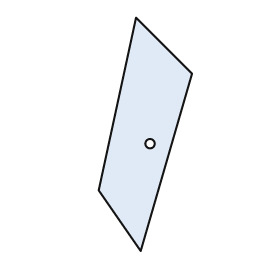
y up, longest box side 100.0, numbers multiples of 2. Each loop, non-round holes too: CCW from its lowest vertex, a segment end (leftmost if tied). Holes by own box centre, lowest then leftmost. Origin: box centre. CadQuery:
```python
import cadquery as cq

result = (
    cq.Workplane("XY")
    .moveTo(-2.0, -50.0)
    .lineTo(20.0, 26.0)
    .lineTo(-4.0, 50.0)
    .lineTo(-20.0, -24.0)
    .close()
    .moveTo(2.0, -4.0)
    .circle(2.0)
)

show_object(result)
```